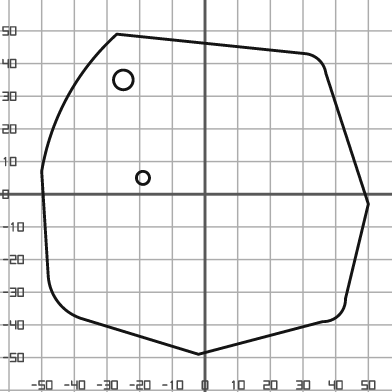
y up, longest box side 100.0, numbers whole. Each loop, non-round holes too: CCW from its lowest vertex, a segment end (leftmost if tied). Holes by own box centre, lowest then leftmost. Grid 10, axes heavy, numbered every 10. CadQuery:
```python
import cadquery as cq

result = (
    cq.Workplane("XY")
    .moveTo(-2.0, -49.0)
    .lineTo(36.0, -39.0)
    .threePointArc((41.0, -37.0), (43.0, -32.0))
    .lineTo(50.0, -3.0)
    .lineTo(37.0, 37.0)
    .threePointArc((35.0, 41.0), (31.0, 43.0))
    .lineTo(-27.0, 49.0)
    .threePointArc((-42.0, 30.0), (-50.0, 7.0))
    .lineTo(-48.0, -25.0)
    .threePointArc((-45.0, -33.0), (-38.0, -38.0))
    .close()
    .moveTo(-19.0, 5.0)
    .circle(2.0)
    .moveTo(-25.0, 35.0)
    .circle(3.0)
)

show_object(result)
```